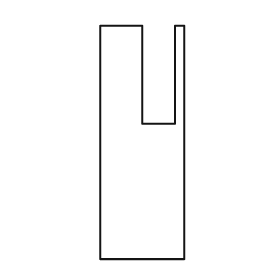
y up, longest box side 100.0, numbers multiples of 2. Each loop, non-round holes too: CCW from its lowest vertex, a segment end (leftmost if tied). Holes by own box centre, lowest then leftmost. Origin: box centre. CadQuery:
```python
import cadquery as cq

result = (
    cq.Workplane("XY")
    .moveTo(-18.0, -50.0)
    .lineTo(18.0, -50.0)
    .lineTo(18.0, 50.0)
    .lineTo(14.0, 50.0)
    .lineTo(14.0, 8.0)
    .lineTo(0.0, 8.0)
    .lineTo(0.0, 50.0)
    .lineTo(-18.0, 50.0)
    .close()
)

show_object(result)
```